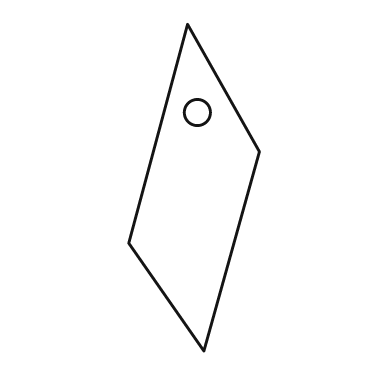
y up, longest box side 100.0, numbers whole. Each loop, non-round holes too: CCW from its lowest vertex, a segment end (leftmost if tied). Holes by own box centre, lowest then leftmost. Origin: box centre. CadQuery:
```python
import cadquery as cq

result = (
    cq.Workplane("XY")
    .moveTo(3.0, -50.0)
    .lineTo(20.0, 11.0)
    .lineTo(-2.0, 50.0)
    .lineTo(-20.0, -17.0)
    .close()
    .moveTo(1.0, 23.0)
    .circle(4.0)
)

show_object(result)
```